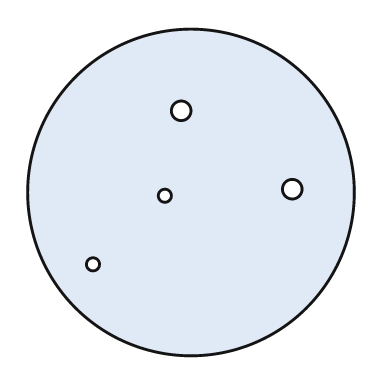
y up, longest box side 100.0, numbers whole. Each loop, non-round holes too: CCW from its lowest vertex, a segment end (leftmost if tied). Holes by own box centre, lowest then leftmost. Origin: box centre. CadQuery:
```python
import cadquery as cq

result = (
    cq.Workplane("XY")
    .moveTo(0.0, 0.0)
    .circle(50.0)
    .moveTo(-30.0, -22.0)
    .circle(2.0)
    .moveTo(-8.0, -1.0)
    .circle(2.0)
    .moveTo(31.0, 1.0)
    .circle(3.0)
    .moveTo(-3.0, 25.0)
    .circle(3.0)
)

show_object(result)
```